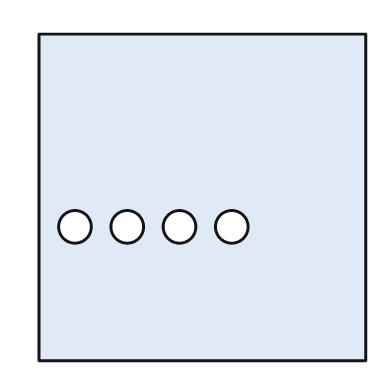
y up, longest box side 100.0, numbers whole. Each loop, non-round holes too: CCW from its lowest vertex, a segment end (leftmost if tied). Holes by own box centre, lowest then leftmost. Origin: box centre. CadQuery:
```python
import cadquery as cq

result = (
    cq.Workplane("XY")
    .moveTo(-50.0, -50.0)
    .lineTo(50.0, -50.0)
    .lineTo(50.0, 50.0)
    .lineTo(-50.0, 50.0)
    .close()
    .moveTo(-39.0, -9.0)
    .circle(5.0)
    .moveTo(-23.0, -9.0)
    .circle(5.0)
    .moveTo(-7.0, -9.0)
    .circle(5.0)
    .moveTo(9.0, -9.0)
    .circle(5.0)
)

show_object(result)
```